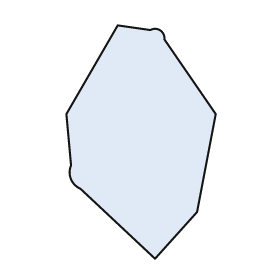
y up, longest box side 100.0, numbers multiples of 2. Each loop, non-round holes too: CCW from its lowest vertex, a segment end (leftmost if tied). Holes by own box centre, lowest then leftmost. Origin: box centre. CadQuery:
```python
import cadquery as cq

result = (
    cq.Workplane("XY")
    .moveTo(6.0, -50.0)
    .lineTo(24.0, -30.0)
    .lineTo(32.0, 12.0)
    .lineTo(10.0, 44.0)
    .threePointArc((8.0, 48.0), (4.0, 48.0))
    .lineTo(-10.0, 50.0)
    .lineTo(-32.0, 12.0)
    .lineTo(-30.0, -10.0)
    .threePointArc((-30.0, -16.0), (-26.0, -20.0))
    .close()
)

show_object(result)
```